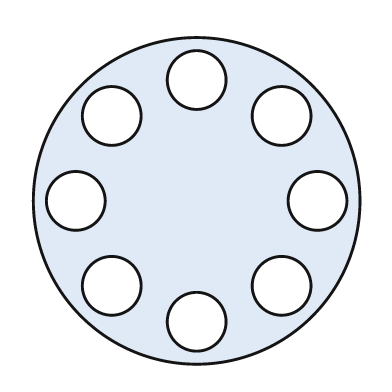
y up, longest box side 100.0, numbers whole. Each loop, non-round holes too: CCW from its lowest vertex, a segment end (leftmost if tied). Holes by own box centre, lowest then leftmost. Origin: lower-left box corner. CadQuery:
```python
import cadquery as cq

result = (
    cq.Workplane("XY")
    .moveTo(50.0, 50.0)
    .circle(50.0)
    .moveTo(50.0, 13.0)
    .circle(9.0)
    .moveTo(24.0, 24.0)
    .circle(9.0)
    .moveTo(76.0, 24.0)
    .circle(9.0)
    .moveTo(13.0, 50.0)
    .circle(9.0)
    .moveTo(87.0, 50.0)
    .circle(9.0)
    .moveTo(24.0, 76.0)
    .circle(9.0)
    .moveTo(76.0, 76.0)
    .circle(9.0)
    .moveTo(50.0, 87.0)
    .circle(9.0)
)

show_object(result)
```